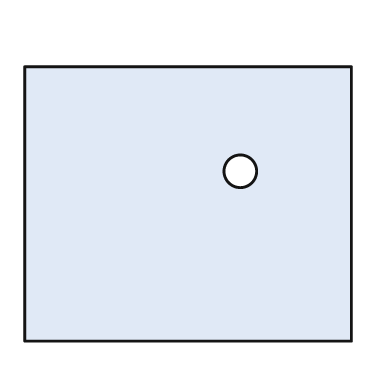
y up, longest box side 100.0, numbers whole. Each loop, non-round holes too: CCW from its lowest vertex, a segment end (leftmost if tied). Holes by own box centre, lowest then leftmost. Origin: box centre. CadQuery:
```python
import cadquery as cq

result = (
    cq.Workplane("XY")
    .moveTo(-50.0, -42.0)
    .lineTo(50.0, -42.0)
    .lineTo(50.0, 42.0)
    .lineTo(-50.0, 42.0)
    .close()
    .moveTo(16.0, 10.0)
    .circle(5.0)
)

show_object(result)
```